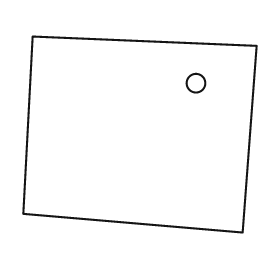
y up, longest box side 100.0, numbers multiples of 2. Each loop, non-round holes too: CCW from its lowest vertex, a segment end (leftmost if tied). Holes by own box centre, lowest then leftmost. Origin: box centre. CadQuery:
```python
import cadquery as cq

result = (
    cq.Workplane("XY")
    .moveTo(44.0, -42.0)
    .lineTo(50.0, 38.0)
    .lineTo(-46.0, 42.0)
    .lineTo(-50.0, -34.0)
    .close()
    .moveTo(24.0, 22.0)
    .circle(4.0)
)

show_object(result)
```